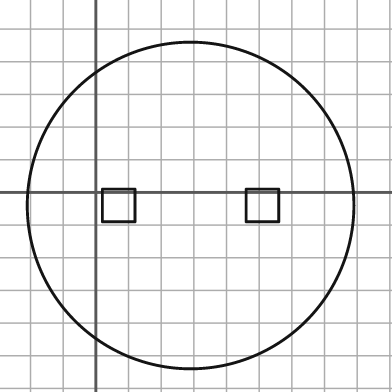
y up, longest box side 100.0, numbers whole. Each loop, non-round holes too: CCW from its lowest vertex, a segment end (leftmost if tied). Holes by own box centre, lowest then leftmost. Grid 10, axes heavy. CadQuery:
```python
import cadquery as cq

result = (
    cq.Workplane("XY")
    .moveTo(29.0, -4.0)
    .circle(50.0)
    .moveTo(2.0, -9.0)
    .lineTo(12.0, -9.0)
    .lineTo(12.0, 1.0)
    .lineTo(2.0, 1.0)
    .close()
    .moveTo(46.0, -9.0)
    .lineTo(56.0, -9.0)
    .lineTo(56.0, 1.0)
    .lineTo(46.0, 1.0)
    .close()
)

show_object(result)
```